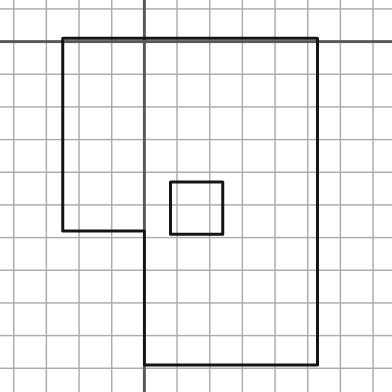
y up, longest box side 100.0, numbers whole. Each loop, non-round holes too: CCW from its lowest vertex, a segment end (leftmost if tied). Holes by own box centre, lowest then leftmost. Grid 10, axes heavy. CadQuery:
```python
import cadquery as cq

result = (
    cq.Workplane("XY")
    .moveTo(0.0, -99.0)
    .lineTo(53.0, -99.0)
    .lineTo(53.0, 1.0)
    .lineTo(-25.0, 1.0)
    .lineTo(-25.0, -58.0)
    .lineTo(0.0, -58.0)
    .close()
    .moveTo(8.0, -59.0)
    .lineTo(24.0, -59.0)
    .lineTo(24.0, -43.0)
    .lineTo(8.0, -43.0)
    .close()
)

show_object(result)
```